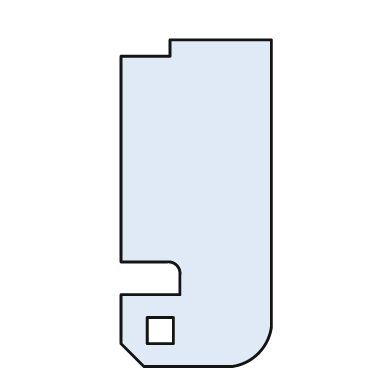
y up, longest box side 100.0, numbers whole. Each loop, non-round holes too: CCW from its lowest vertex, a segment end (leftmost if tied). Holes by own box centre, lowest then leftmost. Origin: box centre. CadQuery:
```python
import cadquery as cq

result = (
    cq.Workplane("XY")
    .moveTo(-16.0, -50.0)
    .lineTo(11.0, -50.0)
    .threePointArc((19.0, -46.0), (23.0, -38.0))
    .lineTo(23.0, 50.0)
    .lineTo(-8.0, 50.0)
    .lineTo(-8.0, 45.0)
    .lineTo(-23.0, 45.0)
    .lineTo(-23.0, -18.0)
    .lineTo(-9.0, -18.0)
    .threePointArc((-6.0, -19.0), (-5.0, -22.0))
    .lineTo(-5.0, -28.0)
    .lineTo(-23.0, -28.0)
    .lineTo(-23.0, -43.0)
    .close()
    .moveTo(-15.0, -43.0)
    .lineTo(-7.0, -43.0)
    .lineTo(-7.0, -35.0)
    .lineTo(-15.0, -35.0)
    .close()
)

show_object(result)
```